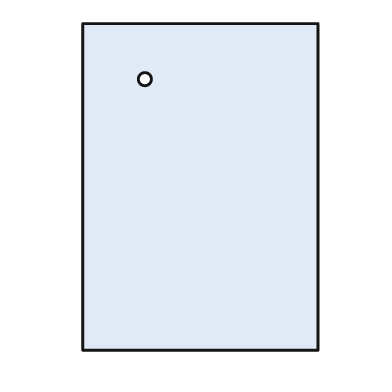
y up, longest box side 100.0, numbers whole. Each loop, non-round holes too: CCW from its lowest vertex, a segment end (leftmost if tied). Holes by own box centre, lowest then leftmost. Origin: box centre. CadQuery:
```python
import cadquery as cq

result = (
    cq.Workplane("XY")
    .moveTo(-36.0, -50.0)
    .lineTo(36.0, -50.0)
    .lineTo(36.0, 50.0)
    .lineTo(-36.0, 50.0)
    .close()
    .moveTo(-17.0, 33.0)
    .circle(2.0)
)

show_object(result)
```